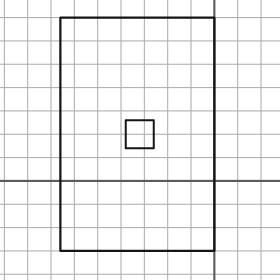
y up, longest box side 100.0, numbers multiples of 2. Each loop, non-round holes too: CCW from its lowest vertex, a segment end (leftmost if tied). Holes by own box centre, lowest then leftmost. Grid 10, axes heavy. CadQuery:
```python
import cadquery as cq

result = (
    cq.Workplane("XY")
    .moveTo(-66.0, -30.0)
    .lineTo(0.0, -30.0)
    .lineTo(0.0, 70.0)
    .lineTo(-66.0, 70.0)
    .close()
    .moveTo(-38.0, 14.0)
    .lineTo(-26.0, 14.0)
    .lineTo(-26.0, 26.0)
    .lineTo(-38.0, 26.0)
    .close()
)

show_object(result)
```